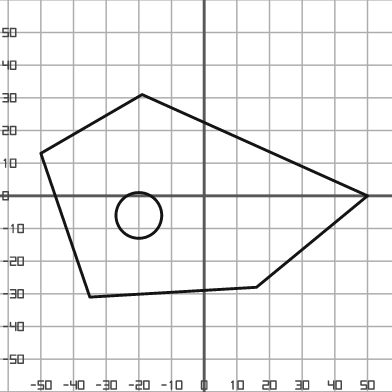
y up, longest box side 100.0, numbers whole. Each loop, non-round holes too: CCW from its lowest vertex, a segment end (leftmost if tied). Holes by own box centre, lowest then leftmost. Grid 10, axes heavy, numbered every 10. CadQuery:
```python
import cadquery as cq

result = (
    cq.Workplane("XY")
    .moveTo(-35.0, -31.0)
    .lineTo(16.0, -28.0)
    .lineTo(50.0, 0.0)
    .lineTo(-19.0, 31.0)
    .lineTo(-50.0, 13.0)
    .close()
    .moveTo(-20.0, -6.0)
    .circle(7.0)
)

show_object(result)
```